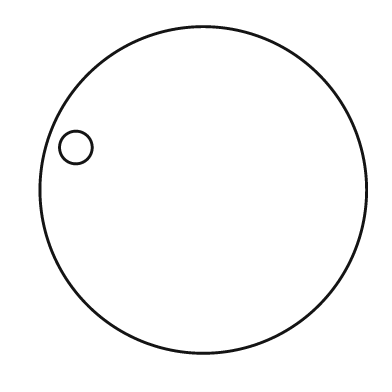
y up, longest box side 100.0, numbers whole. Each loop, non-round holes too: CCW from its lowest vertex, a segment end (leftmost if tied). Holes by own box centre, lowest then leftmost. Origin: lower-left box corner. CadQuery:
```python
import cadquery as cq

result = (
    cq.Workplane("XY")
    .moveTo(50.0, 50.0)
    .circle(50.0)
    .moveTo(11.0, 63.0)
    .circle(5.0)
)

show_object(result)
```